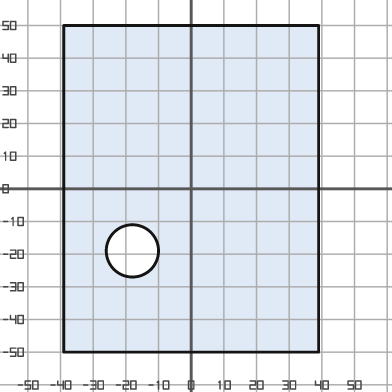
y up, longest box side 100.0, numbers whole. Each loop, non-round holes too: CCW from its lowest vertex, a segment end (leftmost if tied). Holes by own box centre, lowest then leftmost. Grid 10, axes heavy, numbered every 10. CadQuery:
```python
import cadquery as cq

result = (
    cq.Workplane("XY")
    .moveTo(-39.0, -50.0)
    .lineTo(39.0, -50.0)
    .lineTo(39.0, 50.0)
    .lineTo(-39.0, 50.0)
    .close()
    .moveTo(-18.0, -19.0)
    .circle(8.0)
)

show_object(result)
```